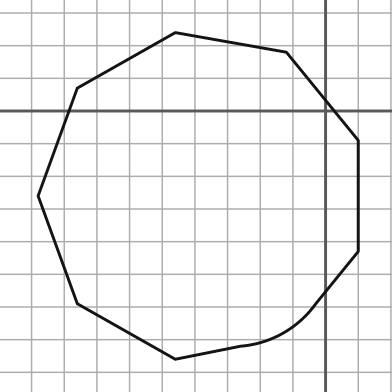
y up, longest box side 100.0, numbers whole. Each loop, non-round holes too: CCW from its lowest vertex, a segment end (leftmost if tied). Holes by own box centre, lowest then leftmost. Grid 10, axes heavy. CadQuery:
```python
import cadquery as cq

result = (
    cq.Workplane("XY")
    .moveTo(-46.0, -76.0)
    .lineTo(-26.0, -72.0)
    .threePointArc((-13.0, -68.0), (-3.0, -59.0))
    .lineTo(10.0, -43.0)
    .lineTo(10.0, -9.0)
    .lineTo(-12.0, 18.0)
    .lineTo(-46.0, 24.0)
    .lineTo(-76.0, 7.0)
    .lineTo(-88.0, -26.0)
    .lineTo(-76.0, -59.0)
    .close()
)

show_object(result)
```